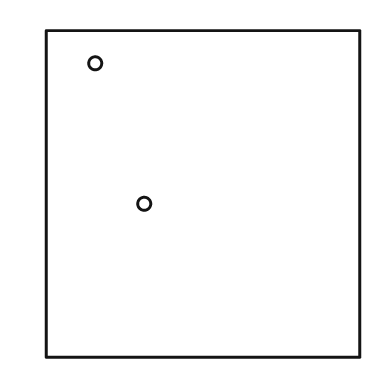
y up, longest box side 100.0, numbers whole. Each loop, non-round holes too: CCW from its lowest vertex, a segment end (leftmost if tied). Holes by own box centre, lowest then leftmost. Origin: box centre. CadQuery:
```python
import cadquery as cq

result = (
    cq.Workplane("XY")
    .moveTo(-48.0, -50.0)
    .lineTo(48.0, -50.0)
    .lineTo(48.0, 50.0)
    .lineTo(-48.0, 50.0)
    .close()
    .moveTo(-18.0, -3.0)
    .circle(2.0)
    .moveTo(-33.0, 40.0)
    .circle(2.0)
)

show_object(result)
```